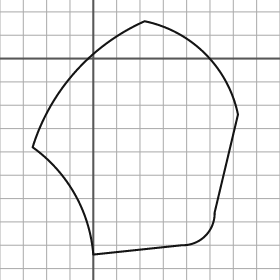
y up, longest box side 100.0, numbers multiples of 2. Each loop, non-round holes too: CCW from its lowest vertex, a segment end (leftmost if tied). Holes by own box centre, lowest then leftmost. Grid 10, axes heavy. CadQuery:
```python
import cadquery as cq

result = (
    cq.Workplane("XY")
    .moveTo(0.0, -84.0)
    .lineTo(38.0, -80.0)
    .threePointArc((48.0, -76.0), (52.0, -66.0))
    .lineTo(62.0, -24.0)
    .threePointArc((48.0, 2.0), (22.0, 16.0))
    .threePointArc((-8.0, -6.0), (-26.0, -38.0))
    .threePointArc((-8.0, -58.0), (0.0, -84.0))
    .close()
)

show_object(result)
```